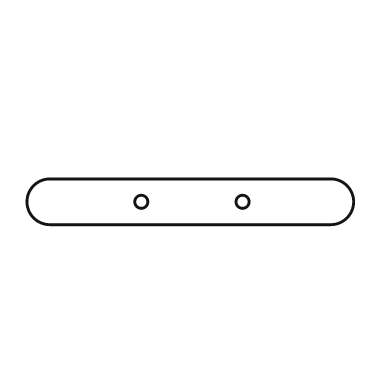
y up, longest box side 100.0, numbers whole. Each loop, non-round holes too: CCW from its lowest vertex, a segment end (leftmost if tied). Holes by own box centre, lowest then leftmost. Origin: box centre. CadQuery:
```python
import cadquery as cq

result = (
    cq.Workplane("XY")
    .moveTo(-43.0, -7.0)
    .lineTo(43.0, -7.0)
    .threePointArc((50.0, 0.0), (43.0, 7.0))
    .lineTo(-43.0, 7.0)
    .threePointArc((-50.0, 0.0), (-43.0, -7.0))
    .close()
    .moveTo(-15.0, 0.0)
    .circle(2.0)
    .moveTo(16.0, 0.0)
    .circle(2.0)
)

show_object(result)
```